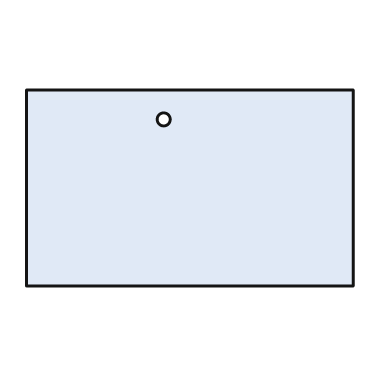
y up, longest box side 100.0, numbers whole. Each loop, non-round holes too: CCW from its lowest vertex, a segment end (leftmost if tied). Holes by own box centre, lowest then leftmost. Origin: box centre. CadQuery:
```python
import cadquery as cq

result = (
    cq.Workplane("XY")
    .moveTo(-50.0, -30.0)
    .lineTo(50.0, -30.0)
    .lineTo(50.0, 30.0)
    .lineTo(-50.0, 30.0)
    .close()
    .moveTo(-8.0, 21.0)
    .circle(2.0)
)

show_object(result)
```